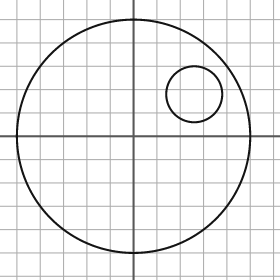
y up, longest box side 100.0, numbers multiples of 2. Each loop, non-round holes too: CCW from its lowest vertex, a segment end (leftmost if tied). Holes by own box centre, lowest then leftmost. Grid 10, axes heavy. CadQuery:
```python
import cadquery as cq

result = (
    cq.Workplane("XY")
    .moveTo(0.0, 0.0)
    .circle(50.0)
    .moveTo(26.0, 18.0)
    .circle(12.0)
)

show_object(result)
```